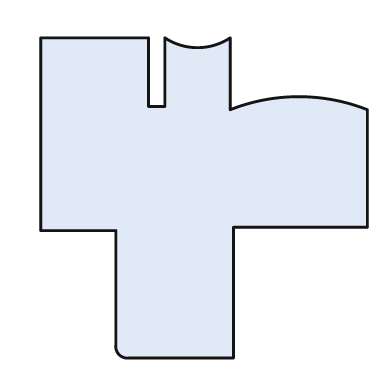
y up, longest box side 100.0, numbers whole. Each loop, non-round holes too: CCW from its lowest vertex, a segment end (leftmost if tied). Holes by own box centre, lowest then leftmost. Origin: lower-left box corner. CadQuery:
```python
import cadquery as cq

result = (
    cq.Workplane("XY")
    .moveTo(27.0, 0.0)
    .lineTo(59.0, 0.0)
    .lineTo(59.0, 40.0)
    .lineTo(100.0, 40.0)
    .lineTo(100.0, 76.0)
    .threePointArc((79.0, 80.0), (58.0, 76.0))
    .lineTo(58.0, 98.0)
    .threePointArc((48.0, 95.0), (38.0, 98.0))
    .lineTo(38.0, 77.0)
    .lineTo(33.0, 77.0)
    .lineTo(33.0, 98.0)
    .lineTo(0.0, 98.0)
    .lineTo(0.0, 39.0)
    .lineTo(23.0, 39.0)
    .lineTo(23.0, 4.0)
    .threePointArc((24.0, 1.0), (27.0, 0.0))
    .close()
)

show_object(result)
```